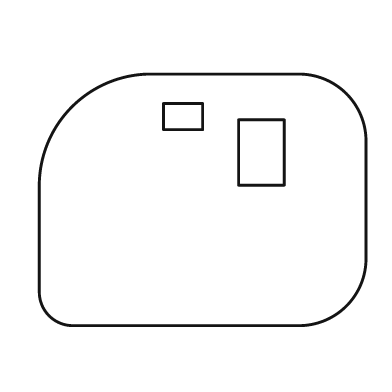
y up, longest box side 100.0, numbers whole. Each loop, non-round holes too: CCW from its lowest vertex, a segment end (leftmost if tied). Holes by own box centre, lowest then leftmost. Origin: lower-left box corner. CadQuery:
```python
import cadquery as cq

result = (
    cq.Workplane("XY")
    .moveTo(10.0, 0.0)
    .lineTo(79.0, 0.0)
    .threePointArc((94.0, 6.0), (100.0, 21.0))
    .lineTo(100.0, 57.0)
    .threePointArc((94.0, 71.0), (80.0, 77.0))
    .lineTo(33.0, 77.0)
    .threePointArc((10.0, 67.0), (0.0, 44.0))
    .lineTo(0.0, 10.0)
    .threePointArc((3.0, 3.0), (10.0, 0.0))
    .close()
    .moveTo(61.0, 43.0)
    .lineTo(75.0, 43.0)
    .lineTo(75.0, 63.0)
    .lineTo(61.0, 63.0)
    .close()
    .moveTo(38.0, 60.0)
    .lineTo(50.0, 60.0)
    .lineTo(50.0, 68.0)
    .lineTo(38.0, 68.0)
    .close()
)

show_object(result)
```